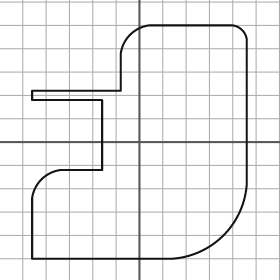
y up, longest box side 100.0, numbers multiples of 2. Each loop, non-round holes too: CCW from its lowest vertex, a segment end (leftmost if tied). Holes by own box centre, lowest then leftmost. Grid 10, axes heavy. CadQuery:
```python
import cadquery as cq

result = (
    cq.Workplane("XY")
    .moveTo(-46.0, -50.0)
    .lineTo(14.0, -50.0)
    .threePointArc((36.0, -40.0), (46.0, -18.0))
    .lineTo(46.0, 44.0)
    .threePointArc((44.0, 48.0), (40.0, 50.0))
    .lineTo(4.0, 50.0)
    .threePointArc((-4.0, 46.0), (-8.0, 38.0))
    .lineTo(-8.0, 22.0)
    .lineTo(-46.0, 22.0)
    .lineTo(-46.0, 18.0)
    .lineTo(-16.0, 18.0)
    .lineTo(-16.0, -12.0)
    .lineTo(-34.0, -12.0)
    .threePointArc((-42.0, -16.0), (-46.0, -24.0))
    .close()
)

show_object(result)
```